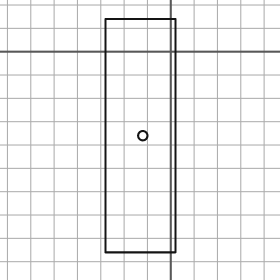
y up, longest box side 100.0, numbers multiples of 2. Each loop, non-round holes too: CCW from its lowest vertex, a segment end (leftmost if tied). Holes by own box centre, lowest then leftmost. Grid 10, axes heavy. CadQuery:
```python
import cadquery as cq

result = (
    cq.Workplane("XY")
    .moveTo(-28.0, -86.0)
    .lineTo(2.0, -86.0)
    .lineTo(2.0, 14.0)
    .lineTo(-28.0, 14.0)
    .close()
    .moveTo(-12.0, -36.0)
    .circle(2.0)
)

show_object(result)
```